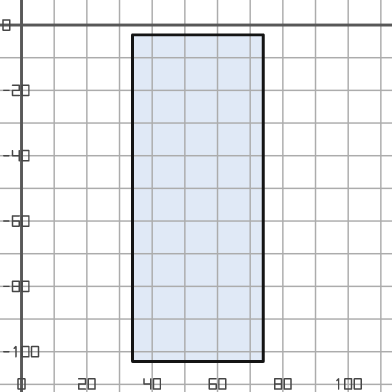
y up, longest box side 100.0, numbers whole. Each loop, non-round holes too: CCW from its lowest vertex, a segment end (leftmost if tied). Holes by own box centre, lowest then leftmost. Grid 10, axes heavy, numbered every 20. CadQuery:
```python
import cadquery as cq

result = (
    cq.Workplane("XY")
    .moveTo(34.0, -103.0)
    .lineTo(74.0, -103.0)
    .lineTo(74.0, -3.0)
    .lineTo(34.0, -3.0)
    .close()
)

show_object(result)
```